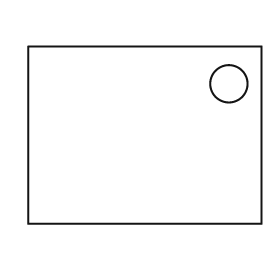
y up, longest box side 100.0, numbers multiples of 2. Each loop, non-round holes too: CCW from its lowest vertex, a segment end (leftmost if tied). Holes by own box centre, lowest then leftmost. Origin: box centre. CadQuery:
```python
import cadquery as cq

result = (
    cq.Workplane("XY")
    .moveTo(-50.0, -38.0)
    .lineTo(50.0, -38.0)
    .lineTo(50.0, 38.0)
    .lineTo(-50.0, 38.0)
    .close()
    .moveTo(36.0, 22.0)
    .circle(8.0)
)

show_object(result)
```